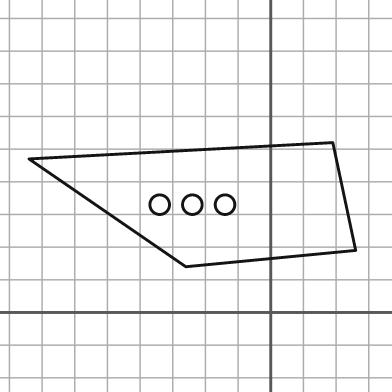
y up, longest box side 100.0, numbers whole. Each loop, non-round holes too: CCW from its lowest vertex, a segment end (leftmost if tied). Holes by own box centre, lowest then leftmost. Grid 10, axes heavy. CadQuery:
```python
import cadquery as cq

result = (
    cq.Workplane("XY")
    .moveTo(-26.0, 14.0)
    .lineTo(26.0, 19.0)
    .lineTo(19.0, 52.0)
    .lineTo(-74.0, 47.0)
    .close()
    .moveTo(-34.0, 33.0)
    .circle(3.0)
    .moveTo(-24.0, 33.0)
    .circle(3.0)
    .moveTo(-14.0, 33.0)
    .circle(3.0)
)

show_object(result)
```